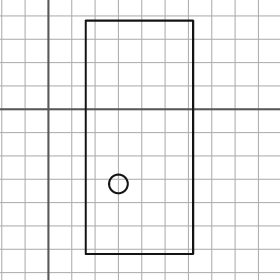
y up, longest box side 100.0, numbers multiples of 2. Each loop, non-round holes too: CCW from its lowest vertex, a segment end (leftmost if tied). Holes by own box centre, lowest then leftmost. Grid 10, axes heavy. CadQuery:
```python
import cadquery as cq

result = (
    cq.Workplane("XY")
    .moveTo(16.0, -62.0)
    .lineTo(62.0, -62.0)
    .lineTo(62.0, 38.0)
    .lineTo(16.0, 38.0)
    .close()
    .moveTo(30.0, -32.0)
    .circle(4.0)
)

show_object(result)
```